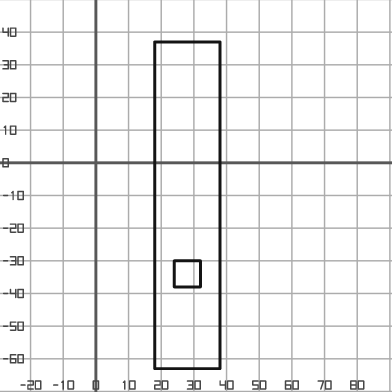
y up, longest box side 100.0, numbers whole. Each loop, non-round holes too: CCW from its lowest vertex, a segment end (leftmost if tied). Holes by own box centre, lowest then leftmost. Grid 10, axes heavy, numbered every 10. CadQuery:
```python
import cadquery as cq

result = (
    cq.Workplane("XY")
    .moveTo(18.0, -63.0)
    .lineTo(38.0, -63.0)
    .lineTo(38.0, 37.0)
    .lineTo(18.0, 37.0)
    .close()
    .moveTo(24.0, -38.0)
    .lineTo(32.0, -38.0)
    .lineTo(32.0, -30.0)
    .lineTo(24.0, -30.0)
    .close()
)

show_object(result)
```